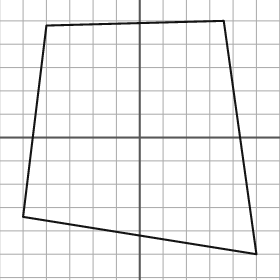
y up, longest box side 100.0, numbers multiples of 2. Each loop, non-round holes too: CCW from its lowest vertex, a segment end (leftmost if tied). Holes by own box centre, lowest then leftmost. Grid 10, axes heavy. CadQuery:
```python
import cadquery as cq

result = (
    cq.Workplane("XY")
    .moveTo(50.0, -50.0)
    .lineTo(36.0, 50.0)
    .lineTo(-40.0, 48.0)
    .lineTo(-50.0, -34.0)
    .close()
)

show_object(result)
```